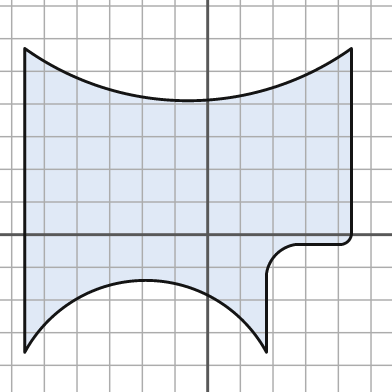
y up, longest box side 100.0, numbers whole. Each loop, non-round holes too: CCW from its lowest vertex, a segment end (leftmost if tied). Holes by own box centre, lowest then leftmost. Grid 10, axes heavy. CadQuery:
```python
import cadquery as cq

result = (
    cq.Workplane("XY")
    .moveTo(-56.0, -36.0)
    .threePointArc((-19.0, -14.0), (18.0, -36.0))
    .lineTo(18.0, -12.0)
    .threePointArc((21.0, -6.0), (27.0, -3.0))
    .lineTo(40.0, -3.0)
    .threePointArc((43.0, -2.0), (44.0, 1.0))
    .lineTo(44.0, 57.0)
    .threePointArc((-6.0, 41.0), (-56.0, 57.0))
    .close()
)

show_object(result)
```